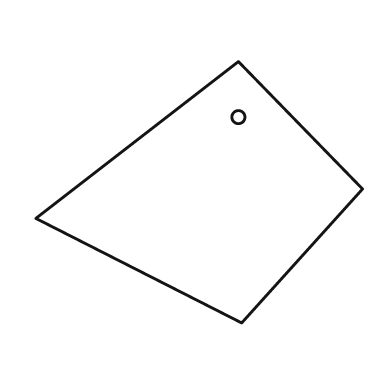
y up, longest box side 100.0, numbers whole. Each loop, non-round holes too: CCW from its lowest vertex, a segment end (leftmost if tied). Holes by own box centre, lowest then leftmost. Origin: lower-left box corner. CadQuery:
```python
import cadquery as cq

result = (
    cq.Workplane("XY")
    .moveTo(63.0, 0.0)
    .lineTo(100.0, 41.0)
    .lineTo(62.0, 80.0)
    .lineTo(0.0, 32.0)
    .close()
    .moveTo(62.0, 63.0)
    .circle(2.0)
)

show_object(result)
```